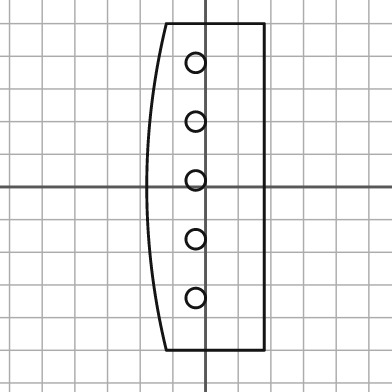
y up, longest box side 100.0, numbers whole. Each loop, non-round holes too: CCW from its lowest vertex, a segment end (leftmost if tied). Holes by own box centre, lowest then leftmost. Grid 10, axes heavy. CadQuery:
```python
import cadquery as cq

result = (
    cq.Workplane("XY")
    .moveTo(-12.0, -50.0)
    .lineTo(18.0, -50.0)
    .lineTo(18.0, 50.0)
    .lineTo(-12.0, 50.0)
    .threePointArc((-18.0, 0.0), (-12.0, -50.0))
    .close()
    .moveTo(-3.0, -34.0)
    .circle(3.0)
    .moveTo(-3.0, -16.0)
    .circle(3.0)
    .moveTo(-3.0, 2.0)
    .circle(3.0)
    .moveTo(-3.0, 20.0)
    .circle(3.0)
    .moveTo(-3.0, 38.0)
    .circle(3.0)
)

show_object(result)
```